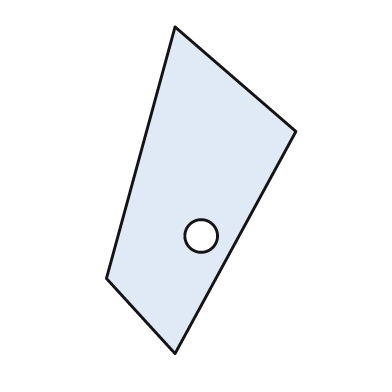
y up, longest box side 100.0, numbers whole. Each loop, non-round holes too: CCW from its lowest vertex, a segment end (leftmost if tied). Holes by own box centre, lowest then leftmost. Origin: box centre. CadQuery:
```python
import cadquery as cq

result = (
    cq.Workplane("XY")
    .moveTo(-8.0, -50.0)
    .lineTo(29.0, 18.0)
    .lineTo(-8.0, 50.0)
    .lineTo(-29.0, -27.0)
    .close()
    .moveTo(0.0, -14.0)
    .circle(5.0)
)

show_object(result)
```